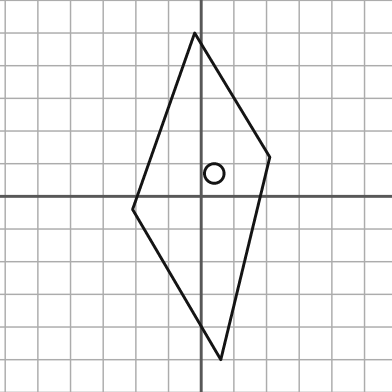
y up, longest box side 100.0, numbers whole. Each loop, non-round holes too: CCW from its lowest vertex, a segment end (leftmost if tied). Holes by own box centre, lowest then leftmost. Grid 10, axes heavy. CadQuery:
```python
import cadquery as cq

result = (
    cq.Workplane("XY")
    .moveTo(6.0, -50.0)
    .lineTo(21.0, 12.0)
    .lineTo(-2.0, 50.0)
    .lineTo(-21.0, -4.0)
    .close()
    .moveTo(4.0, 7.0)
    .circle(3.0)
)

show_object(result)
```